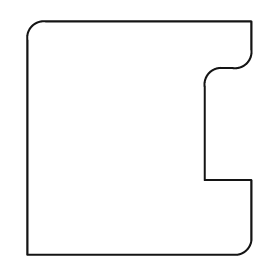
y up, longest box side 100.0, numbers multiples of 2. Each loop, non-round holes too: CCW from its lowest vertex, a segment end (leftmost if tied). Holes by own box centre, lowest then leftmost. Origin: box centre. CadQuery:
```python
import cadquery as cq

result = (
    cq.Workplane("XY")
    .moveTo(-48.0, -50.0)
    .lineTo(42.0, -50.0)
    .threePointArc((46.0, -48.0), (48.0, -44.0))
    .lineTo(48.0, -18.0)
    .lineTo(28.0, -18.0)
    .lineTo(28.0, 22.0)
    .threePointArc((30.0, 28.0), (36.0, 30.0))
    .lineTo(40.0, 30.0)
    .threePointArc((46.0, 32.0), (48.0, 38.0))
    .lineTo(48.0, 50.0)
    .lineTo(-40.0, 50.0)
    .threePointArc((-46.0, 48.0), (-48.0, 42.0))
    .close()
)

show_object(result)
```